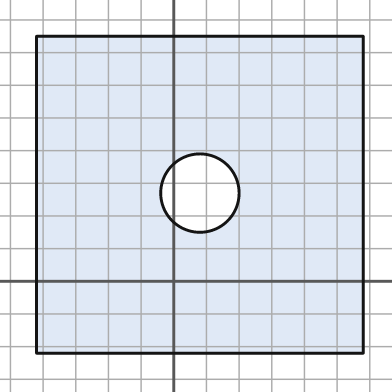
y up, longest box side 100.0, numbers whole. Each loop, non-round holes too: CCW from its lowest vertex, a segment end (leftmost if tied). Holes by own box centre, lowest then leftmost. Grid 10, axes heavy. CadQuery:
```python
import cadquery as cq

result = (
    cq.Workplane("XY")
    .moveTo(-42.0, -22.0)
    .lineTo(58.0, -22.0)
    .lineTo(58.0, 75.0)
    .lineTo(-42.0, 75.0)
    .close()
    .moveTo(8.0, 27.0)
    .circle(12.0)
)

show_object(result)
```